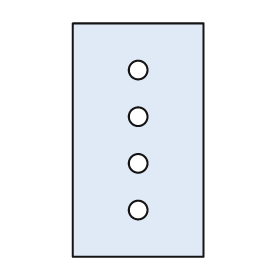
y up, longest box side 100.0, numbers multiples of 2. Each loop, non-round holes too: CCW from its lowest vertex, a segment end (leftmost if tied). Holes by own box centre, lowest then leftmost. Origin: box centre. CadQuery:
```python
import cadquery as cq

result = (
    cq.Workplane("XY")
    .moveTo(-28.0, -50.0)
    .lineTo(28.0, -50.0)
    .lineTo(28.0, 50.0)
    .lineTo(-28.0, 50.0)
    .close()
    .moveTo(0.0, -30.0)
    .circle(4.0)
    .moveTo(0.0, -10.0)
    .circle(4.0)
    .moveTo(0.0, 10.0)
    .circle(4.0)
    .moveTo(0.0, 30.0)
    .circle(4.0)
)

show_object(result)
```